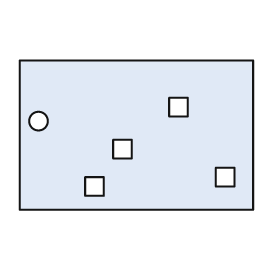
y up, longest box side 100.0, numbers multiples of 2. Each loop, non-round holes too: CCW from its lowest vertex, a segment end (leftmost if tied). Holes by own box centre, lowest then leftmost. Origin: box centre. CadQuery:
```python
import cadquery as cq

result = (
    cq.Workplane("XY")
    .moveTo(-50.0, -32.0)
    .lineTo(50.0, -32.0)
    .lineTo(50.0, 32.0)
    .lineTo(-50.0, 32.0)
    .close()
    .moveTo(-22.0, -26.0)
    .lineTo(-14.0, -26.0)
    .lineTo(-14.0, -18.0)
    .lineTo(-22.0, -18.0)
    .close()
    .moveTo(34.0, -22.0)
    .lineTo(42.0, -22.0)
    .lineTo(42.0, -14.0)
    .lineTo(34.0, -14.0)
    .close()
    .moveTo(-10.0, -10.0)
    .lineTo(-2.0, -10.0)
    .lineTo(-2.0, -2.0)
    .lineTo(-10.0, -2.0)
    .close()
    .moveTo(-42.0, 6.0)
    .circle(4.0)
    .moveTo(14.0, 8.0)
    .lineTo(22.0, 8.0)
    .lineTo(22.0, 16.0)
    .lineTo(14.0, 16.0)
    .close()
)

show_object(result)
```